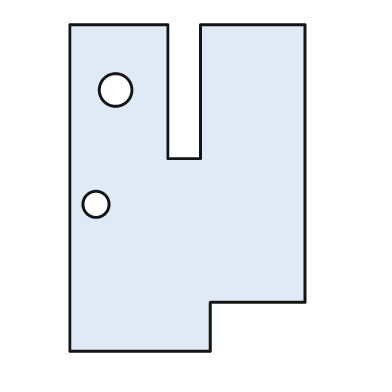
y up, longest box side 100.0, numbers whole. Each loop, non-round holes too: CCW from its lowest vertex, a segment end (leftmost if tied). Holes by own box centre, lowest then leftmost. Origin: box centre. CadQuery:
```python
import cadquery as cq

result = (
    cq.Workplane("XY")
    .moveTo(-36.0, -50.0)
    .lineTo(7.0, -50.0)
    .lineTo(7.0, -35.0)
    .lineTo(36.0, -35.0)
    .lineTo(36.0, 50.0)
    .lineTo(4.0, 50.0)
    .lineTo(4.0, 9.0)
    .lineTo(-6.0, 9.0)
    .lineTo(-6.0, 50.0)
    .lineTo(-36.0, 50.0)
    .close()
    .moveTo(-28.0, -5.0)
    .circle(4.0)
    .moveTo(-22.0, 30.0)
    .circle(5.0)
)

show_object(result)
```